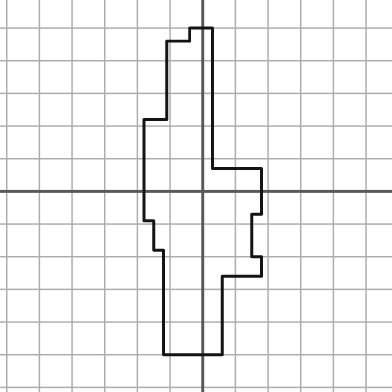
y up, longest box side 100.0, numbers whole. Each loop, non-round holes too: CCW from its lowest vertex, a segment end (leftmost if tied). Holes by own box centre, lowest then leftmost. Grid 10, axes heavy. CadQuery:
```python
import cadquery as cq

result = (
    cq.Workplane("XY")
    .moveTo(-12.0, -50.0)
    .lineTo(6.0, -50.0)
    .lineTo(6.0, -26.0)
    .lineTo(18.0, -26.0)
    .lineTo(18.0, -20.0)
    .lineTo(15.0, -20.0)
    .lineTo(15.0, -7.0)
    .lineTo(18.0, -7.0)
    .lineTo(18.0, 7.0)
    .lineTo(3.0, 7.0)
    .lineTo(3.0, 50.0)
    .lineTo(-4.0, 50.0)
    .lineTo(-4.0, 46.0)
    .lineTo(-11.0, 46.0)
    .lineTo(-11.0, 22.0)
    .lineTo(-18.0, 22.0)
    .lineTo(-18.0, -9.0)
    .lineTo(-15.0, -9.0)
    .lineTo(-15.0, -18.0)
    .lineTo(-12.0, -18.0)
    .close()
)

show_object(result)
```